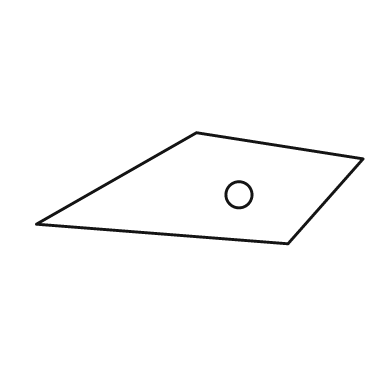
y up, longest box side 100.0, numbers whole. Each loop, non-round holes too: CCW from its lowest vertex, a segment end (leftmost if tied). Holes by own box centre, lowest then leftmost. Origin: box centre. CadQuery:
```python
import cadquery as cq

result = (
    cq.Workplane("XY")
    .moveTo(27.0, -17.0)
    .lineTo(50.0, 9.0)
    .lineTo(-1.0, 17.0)
    .lineTo(-50.0, -11.0)
    .close()
    .moveTo(12.0, -2.0)
    .circle(4.0)
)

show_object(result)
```